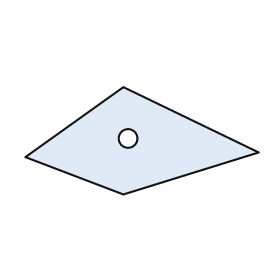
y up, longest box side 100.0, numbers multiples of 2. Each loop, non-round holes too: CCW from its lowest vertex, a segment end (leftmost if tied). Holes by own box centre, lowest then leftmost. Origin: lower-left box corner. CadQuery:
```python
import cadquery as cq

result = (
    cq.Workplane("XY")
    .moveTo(42.0, 0.0)
    .lineTo(100.0, 18.0)
    .lineTo(42.0, 46.0)
    .lineTo(0.0, 16.0)
    .close()
    .moveTo(44.0, 24.0)
    .circle(4.0)
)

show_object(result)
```